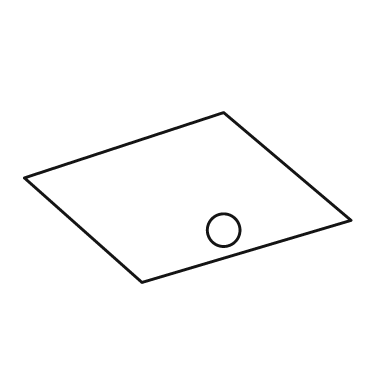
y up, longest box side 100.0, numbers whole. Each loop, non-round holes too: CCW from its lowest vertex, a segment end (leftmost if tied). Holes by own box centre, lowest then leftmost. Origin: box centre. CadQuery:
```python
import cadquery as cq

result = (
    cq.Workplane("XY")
    .moveTo(-14.0, -26.0)
    .lineTo(50.0, -7.0)
    .lineTo(11.0, 26.0)
    .lineTo(-50.0, 6.0)
    .close()
    .moveTo(11.0, -10.0)
    .circle(5.0)
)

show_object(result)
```